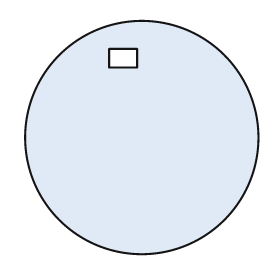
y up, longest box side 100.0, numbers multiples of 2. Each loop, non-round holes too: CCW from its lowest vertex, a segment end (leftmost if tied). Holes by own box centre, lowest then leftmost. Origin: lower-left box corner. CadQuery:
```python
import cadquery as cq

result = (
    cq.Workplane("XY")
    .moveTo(50.0, 50.0)
    .circle(50.0)
    .moveTo(36.0, 80.0)
    .lineTo(48.0, 80.0)
    .lineTo(48.0, 88.0)
    .lineTo(36.0, 88.0)
    .close()
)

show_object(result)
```